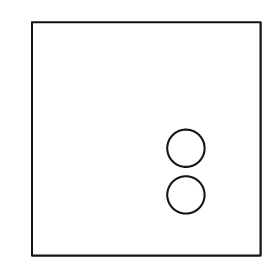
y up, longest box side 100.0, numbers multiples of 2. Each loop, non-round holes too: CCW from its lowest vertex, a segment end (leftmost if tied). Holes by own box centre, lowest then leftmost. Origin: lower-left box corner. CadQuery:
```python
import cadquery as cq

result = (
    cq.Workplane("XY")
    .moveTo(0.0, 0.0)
    .lineTo(98.0, 0.0)
    .lineTo(98.0, 100.0)
    .lineTo(0.0, 100.0)
    .close()
    .moveTo(66.0, 26.0)
    .circle(8.0)
    .moveTo(66.0, 46.0)
    .circle(8.0)
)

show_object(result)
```